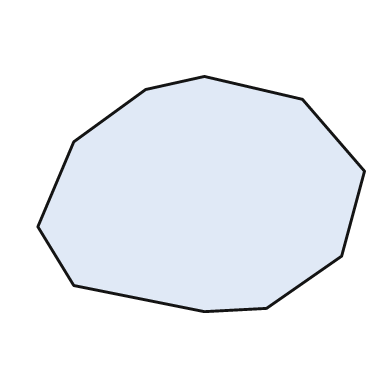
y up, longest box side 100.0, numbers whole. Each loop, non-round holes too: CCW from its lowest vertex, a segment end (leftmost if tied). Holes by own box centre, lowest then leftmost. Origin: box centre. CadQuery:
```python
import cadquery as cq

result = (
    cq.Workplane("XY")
    .moveTo(1.0, -36.0)
    .lineTo(20.0, -35.0)
    .lineTo(43.0, -19.0)
    .lineTo(50.0, 7.0)
    .lineTo(31.0, 29.0)
    .lineTo(1.0, 36.0)
    .lineTo(-17.0, 32.0)
    .lineTo(-39.0, 16.0)
    .lineTo(-50.0, -10.0)
    .lineTo(-39.0, -28.0)
    .close()
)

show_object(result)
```